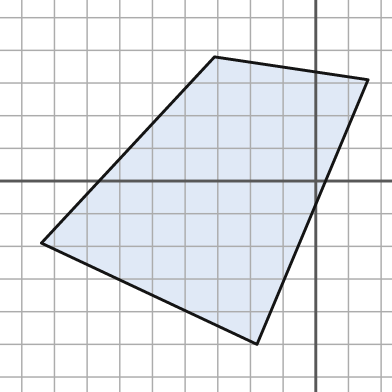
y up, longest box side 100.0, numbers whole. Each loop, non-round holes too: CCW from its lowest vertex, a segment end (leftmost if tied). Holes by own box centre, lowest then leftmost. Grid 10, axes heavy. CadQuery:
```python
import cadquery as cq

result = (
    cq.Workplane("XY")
    .moveTo(-18.0, -50.0)
    .lineTo(16.0, 31.0)
    .lineTo(-31.0, 38.0)
    .lineTo(-84.0, -19.0)
    .close()
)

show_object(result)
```